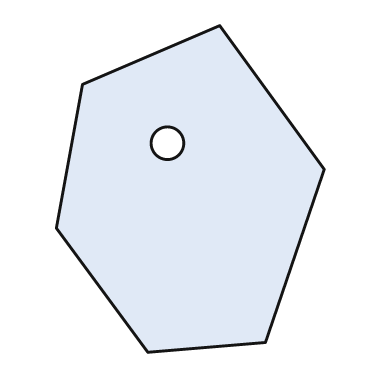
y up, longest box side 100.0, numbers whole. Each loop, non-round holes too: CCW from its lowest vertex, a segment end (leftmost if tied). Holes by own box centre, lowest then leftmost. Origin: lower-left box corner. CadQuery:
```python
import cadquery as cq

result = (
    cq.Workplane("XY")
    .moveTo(28.0, 0.0)
    .lineTo(64.0, 3.0)
    .lineTo(82.0, 56.0)
    .lineTo(50.0, 100.0)
    .lineTo(8.0, 82.0)
    .lineTo(0.0, 38.0)
    .close()
    .moveTo(34.0, 64.0)
    .circle(5.0)
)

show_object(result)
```